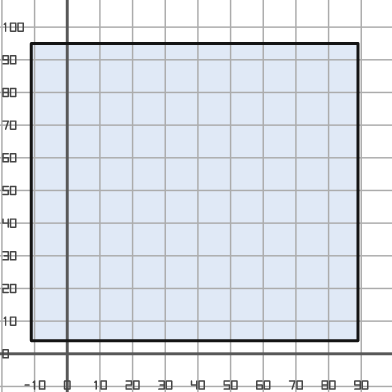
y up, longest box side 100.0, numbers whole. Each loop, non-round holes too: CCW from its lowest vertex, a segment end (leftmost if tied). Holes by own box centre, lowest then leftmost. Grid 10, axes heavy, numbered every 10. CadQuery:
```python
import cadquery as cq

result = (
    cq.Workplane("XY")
    .moveTo(-11.0, 4.0)
    .lineTo(89.0, 4.0)
    .lineTo(89.0, 95.0)
    .lineTo(-11.0, 95.0)
    .close()
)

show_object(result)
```